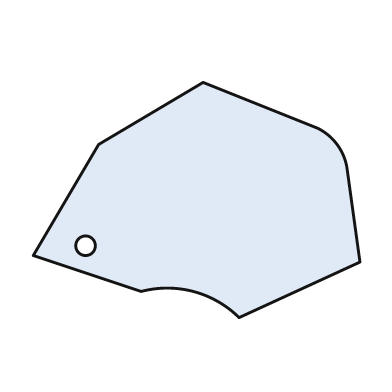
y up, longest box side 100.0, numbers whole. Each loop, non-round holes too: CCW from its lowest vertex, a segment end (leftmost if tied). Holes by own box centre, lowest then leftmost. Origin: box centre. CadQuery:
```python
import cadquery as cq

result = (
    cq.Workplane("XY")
    .moveTo(13.0, -36.0)
    .lineTo(50.0, -19.0)
    .lineTo(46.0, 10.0)
    .threePointArc((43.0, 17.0), (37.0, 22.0))
    .lineTo(2.0, 36.0)
    .lineTo(-30.0, 17.0)
    .lineTo(-50.0, -17.0)
    .lineTo(-17.0, -28.0)
    .threePointArc((-1.0, -28.0), (13.0, -36.0))
    .close()
    .moveTo(-34.0, -14.0)
    .circle(3.0)
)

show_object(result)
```